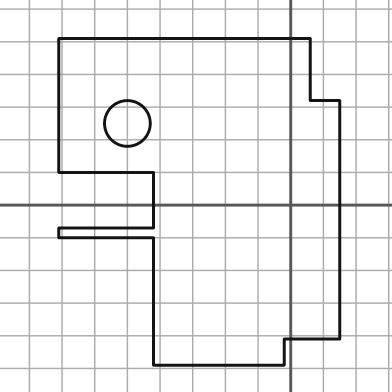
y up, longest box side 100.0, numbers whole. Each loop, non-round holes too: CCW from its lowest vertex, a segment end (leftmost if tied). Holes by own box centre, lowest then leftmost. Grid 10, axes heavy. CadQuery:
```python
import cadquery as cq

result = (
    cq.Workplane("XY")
    .moveTo(-42.0, -49.0)
    .lineTo(-2.0, -49.0)
    .lineTo(-2.0, -41.0)
    .lineTo(15.0, -41.0)
    .lineTo(15.0, 32.0)
    .lineTo(6.0, 32.0)
    .lineTo(6.0, 51.0)
    .lineTo(-71.0, 51.0)
    .lineTo(-71.0, 10.0)
    .lineTo(-42.0, 10.0)
    .lineTo(-42.0, -7.0)
    .lineTo(-71.0, -7.0)
    .lineTo(-71.0, -10.0)
    .lineTo(-42.0, -10.0)
    .close()
    .moveTo(-50.0, 25.0)
    .circle(7.0)
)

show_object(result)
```